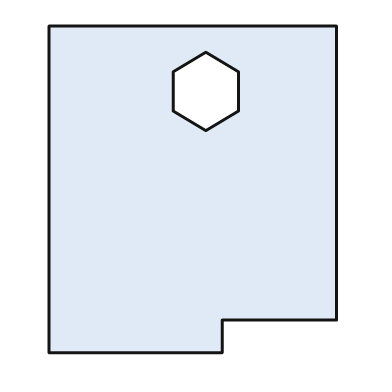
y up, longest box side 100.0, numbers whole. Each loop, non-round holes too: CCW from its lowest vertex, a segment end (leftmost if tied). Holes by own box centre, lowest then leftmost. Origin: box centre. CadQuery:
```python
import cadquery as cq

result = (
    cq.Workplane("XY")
    .moveTo(-44.0, -50.0)
    .lineTo(9.0, -50.0)
    .lineTo(9.0, -40.0)
    .lineTo(44.0, -40.0)
    .lineTo(44.0, 50.0)
    .lineTo(-44.0, 50.0)
    .close()
    .moveTo(4.0, 18.0)
    .lineTo(14.0, 24.0)
    .lineTo(14.0, 36.0)
    .lineTo(4.0, 42.0)
    .lineTo(-6.0, 36.0)
    .lineTo(-6.0, 24.0)
    .close()
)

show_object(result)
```